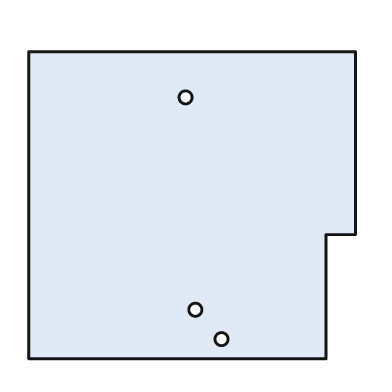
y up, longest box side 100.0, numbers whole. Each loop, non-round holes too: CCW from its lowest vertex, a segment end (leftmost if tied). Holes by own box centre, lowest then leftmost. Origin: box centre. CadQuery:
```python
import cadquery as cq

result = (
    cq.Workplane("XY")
    .moveTo(-50.0, -47.0)
    .lineTo(41.0, -47.0)
    .lineTo(41.0, -9.0)
    .lineTo(50.0, -9.0)
    .lineTo(50.0, 47.0)
    .lineTo(-50.0, 47.0)
    .close()
    .moveTo(9.0, -41.0)
    .circle(2.0)
    .moveTo(1.0, -32.0)
    .circle(2.0)
    .moveTo(-2.0, 33.0)
    .circle(2.0)
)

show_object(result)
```